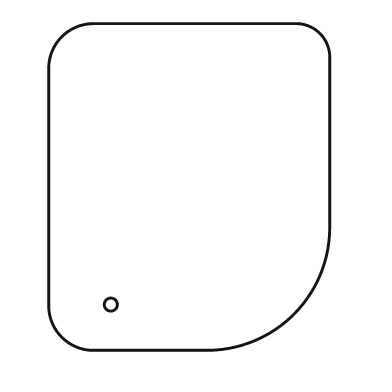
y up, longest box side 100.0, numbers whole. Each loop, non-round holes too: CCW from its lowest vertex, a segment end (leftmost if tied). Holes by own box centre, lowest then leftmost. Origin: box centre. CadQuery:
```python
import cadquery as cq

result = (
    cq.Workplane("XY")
    .moveTo(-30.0, -50.0)
    .lineTo(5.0, -50.0)
    .threePointArc((32.0, -39.0), (43.0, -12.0))
    .lineTo(43.0, 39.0)
    .threePointArc((40.0, 47.0), (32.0, 50.0))
    .lineTo(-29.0, 50.0)
    .threePointArc((-39.0, 46.0), (-43.0, 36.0))
    .lineTo(-43.0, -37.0)
    .threePointArc((-39.0, -46.0), (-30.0, -50.0))
    .close()
    .moveTo(-24.0, -36.0)
    .circle(2.0)
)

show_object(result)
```